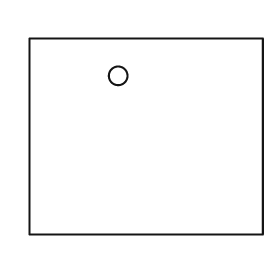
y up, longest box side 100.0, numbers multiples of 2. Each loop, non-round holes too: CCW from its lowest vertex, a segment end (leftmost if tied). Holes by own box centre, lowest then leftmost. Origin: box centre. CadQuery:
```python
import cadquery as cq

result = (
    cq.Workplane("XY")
    .moveTo(-50.0, -42.0)
    .lineTo(50.0, -42.0)
    .lineTo(50.0, 42.0)
    .lineTo(-50.0, 42.0)
    .close()
    .moveTo(-12.0, 26.0)
    .circle(4.0)
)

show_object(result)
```